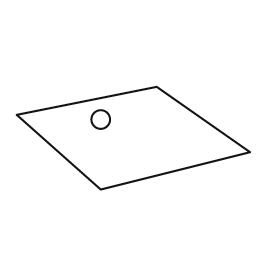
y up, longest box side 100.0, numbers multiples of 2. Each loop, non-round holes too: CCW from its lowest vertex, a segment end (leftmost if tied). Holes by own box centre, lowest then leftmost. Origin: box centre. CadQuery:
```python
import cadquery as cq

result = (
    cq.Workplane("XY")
    .moveTo(-14.0, -22.0)
    .lineTo(50.0, -6.0)
    .lineTo(10.0, 22.0)
    .lineTo(-50.0, 10.0)
    .close()
    .moveTo(-14.0, 8.0)
    .circle(4.0)
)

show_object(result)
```